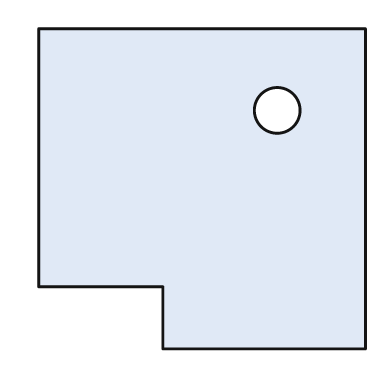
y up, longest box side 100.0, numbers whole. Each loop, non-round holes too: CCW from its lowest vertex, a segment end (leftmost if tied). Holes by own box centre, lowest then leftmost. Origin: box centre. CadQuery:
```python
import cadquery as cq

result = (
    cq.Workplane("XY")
    .moveTo(-12.0, -49.0)
    .lineTo(50.0, -49.0)
    .lineTo(50.0, 49.0)
    .lineTo(-50.0, 49.0)
    .lineTo(-50.0, -30.0)
    .lineTo(-12.0, -30.0)
    .close()
    .moveTo(23.0, 24.0)
    .circle(7.0)
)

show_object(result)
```